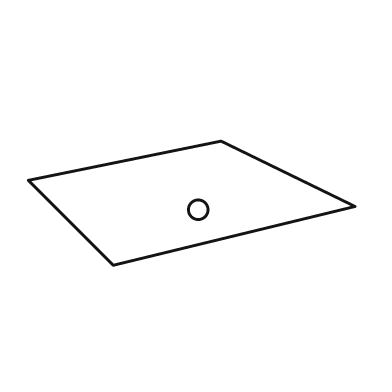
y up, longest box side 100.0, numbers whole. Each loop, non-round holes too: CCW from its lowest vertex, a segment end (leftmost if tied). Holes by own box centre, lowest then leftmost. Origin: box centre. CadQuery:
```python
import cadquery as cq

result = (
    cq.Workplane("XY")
    .moveTo(-24.0, -19.0)
    .lineTo(50.0, -1.0)
    .lineTo(9.0, 19.0)
    .lineTo(-50.0, 7.0)
    .close()
    .moveTo(2.0, -2.0)
    .circle(3.0)
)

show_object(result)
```